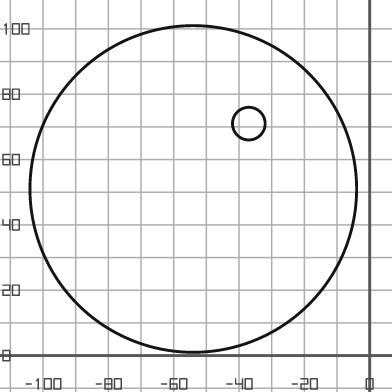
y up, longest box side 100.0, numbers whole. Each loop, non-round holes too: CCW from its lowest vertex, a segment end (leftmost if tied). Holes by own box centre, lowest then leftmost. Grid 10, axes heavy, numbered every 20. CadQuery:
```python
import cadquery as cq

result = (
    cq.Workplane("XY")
    .moveTo(-54.0, 51.0)
    .circle(50.0)
    .moveTo(-37.0, 71.0)
    .circle(5.0)
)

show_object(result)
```